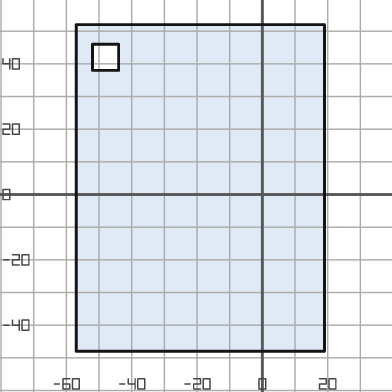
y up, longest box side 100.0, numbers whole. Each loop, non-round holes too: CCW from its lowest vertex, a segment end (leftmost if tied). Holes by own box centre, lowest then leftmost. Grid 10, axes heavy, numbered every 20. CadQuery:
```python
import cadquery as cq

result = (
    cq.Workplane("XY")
    .moveTo(-57.0, -48.0)
    .lineTo(19.0, -48.0)
    .lineTo(19.0, 52.0)
    .lineTo(-57.0, 52.0)
    .close()
    .moveTo(-52.0, 38.0)
    .lineTo(-44.0, 38.0)
    .lineTo(-44.0, 46.0)
    .lineTo(-52.0, 46.0)
    .close()
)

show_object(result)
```